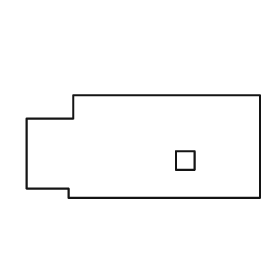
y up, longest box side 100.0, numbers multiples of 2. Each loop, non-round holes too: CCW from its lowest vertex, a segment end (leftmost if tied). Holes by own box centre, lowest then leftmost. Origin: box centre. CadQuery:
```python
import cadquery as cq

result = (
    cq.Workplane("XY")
    .moveTo(-32.0, -22.0)
    .lineTo(50.0, -22.0)
    .lineTo(50.0, 22.0)
    .lineTo(-30.0, 22.0)
    .lineTo(-30.0, 12.0)
    .lineTo(-50.0, 12.0)
    .lineTo(-50.0, -18.0)
    .lineTo(-32.0, -18.0)
    .close()
    .moveTo(14.0, -10.0)
    .lineTo(22.0, -10.0)
    .lineTo(22.0, -2.0)
    .lineTo(14.0, -2.0)
    .close()
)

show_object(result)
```